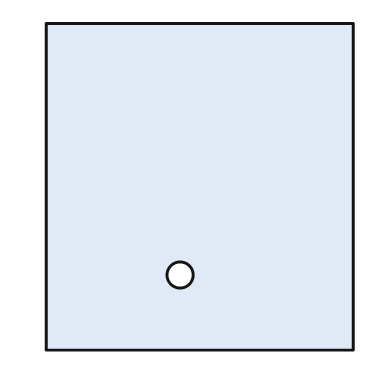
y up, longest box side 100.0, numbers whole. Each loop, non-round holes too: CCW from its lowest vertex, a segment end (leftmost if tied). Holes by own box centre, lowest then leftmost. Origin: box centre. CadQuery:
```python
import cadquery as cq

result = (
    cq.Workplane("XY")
    .moveTo(-47.0, -50.0)
    .lineTo(47.0, -50.0)
    .lineTo(47.0, 50.0)
    .lineTo(-47.0, 50.0)
    .close()
    .moveTo(-6.0, -27.0)
    .circle(4.0)
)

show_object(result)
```